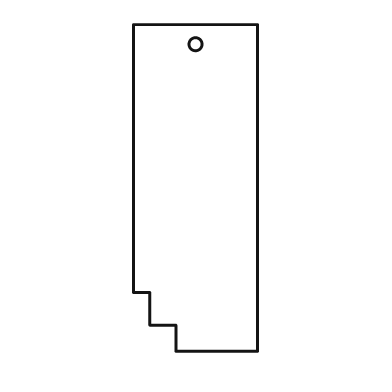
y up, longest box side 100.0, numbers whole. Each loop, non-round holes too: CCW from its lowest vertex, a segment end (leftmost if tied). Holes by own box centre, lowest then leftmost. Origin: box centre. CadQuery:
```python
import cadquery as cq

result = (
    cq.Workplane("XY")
    .moveTo(-6.0, -50.0)
    .lineTo(19.0, -50.0)
    .lineTo(19.0, 50.0)
    .lineTo(-19.0, 50.0)
    .lineTo(-19.0, -32.0)
    .lineTo(-14.0, -32.0)
    .lineTo(-14.0, -42.0)
    .lineTo(-6.0, -42.0)
    .close()
    .moveTo(0.0, 44.0)
    .circle(2.0)
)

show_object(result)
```